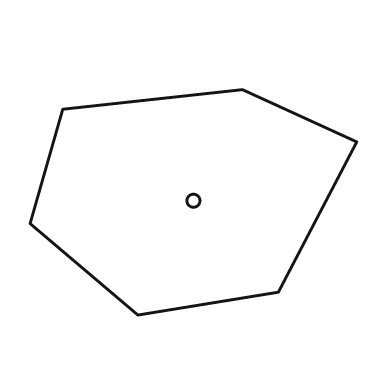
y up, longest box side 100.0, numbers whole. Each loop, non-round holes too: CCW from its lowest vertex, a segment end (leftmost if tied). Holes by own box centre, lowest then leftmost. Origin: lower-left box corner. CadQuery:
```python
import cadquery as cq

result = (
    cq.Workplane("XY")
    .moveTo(33.0, 0.0)
    .lineTo(76.0, 7.0)
    .lineTo(100.0, 53.0)
    .lineTo(65.0, 69.0)
    .lineTo(10.0, 63.0)
    .lineTo(0.0, 28.0)
    .close()
    .moveTo(50.0, 35.0)
    .circle(2.0)
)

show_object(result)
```